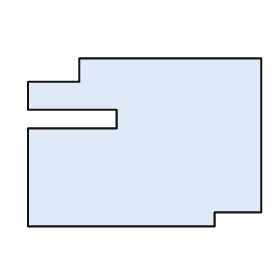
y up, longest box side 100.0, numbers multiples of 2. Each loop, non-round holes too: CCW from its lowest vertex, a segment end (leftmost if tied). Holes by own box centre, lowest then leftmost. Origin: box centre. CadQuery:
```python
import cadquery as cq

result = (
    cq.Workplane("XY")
    .moveTo(-50.0, -36.0)
    .lineTo(30.0, -36.0)
    .lineTo(30.0, -30.0)
    .lineTo(50.0, -30.0)
    .lineTo(50.0, 36.0)
    .lineTo(-28.0, 36.0)
    .lineTo(-28.0, 26.0)
    .lineTo(-50.0, 26.0)
    .lineTo(-50.0, 14.0)
    .lineTo(-12.0, 14.0)
    .lineTo(-12.0, 6.0)
    .lineTo(-50.0, 6.0)
    .close()
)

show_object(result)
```